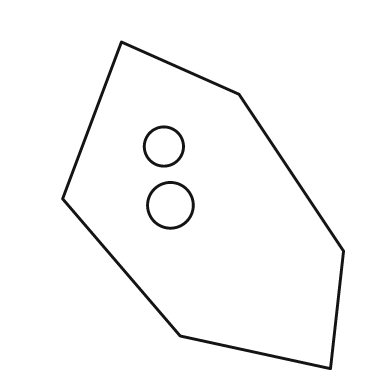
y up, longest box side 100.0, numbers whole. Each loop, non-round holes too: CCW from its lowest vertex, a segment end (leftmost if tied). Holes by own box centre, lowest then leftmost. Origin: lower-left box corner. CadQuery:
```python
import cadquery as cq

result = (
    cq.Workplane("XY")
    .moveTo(82.0, 0.0)
    .lineTo(86.0, 36.0)
    .lineTo(54.0, 84.0)
    .lineTo(18.0, 100.0)
    .lineTo(0.0, 52.0)
    .lineTo(36.0, 10.0)
    .close()
    .moveTo(33.0, 50.0)
    .circle(7.0)
    .moveTo(31.0, 68.0)
    .circle(6.0)
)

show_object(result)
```